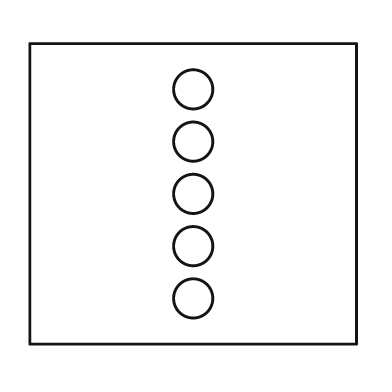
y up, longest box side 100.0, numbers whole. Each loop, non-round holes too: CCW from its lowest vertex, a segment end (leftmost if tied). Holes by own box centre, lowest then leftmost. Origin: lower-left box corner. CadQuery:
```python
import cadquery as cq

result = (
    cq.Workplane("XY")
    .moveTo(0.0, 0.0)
    .lineTo(100.0, 0.0)
    .lineTo(100.0, 92.0)
    .lineTo(0.0, 92.0)
    .close()
    .moveTo(50.0, 14.0)
    .circle(6.0)
    .moveTo(50.0, 30.0)
    .circle(6.0)
    .moveTo(50.0, 46.0)
    .circle(6.0)
    .moveTo(50.0, 62.0)
    .circle(6.0)
    .moveTo(50.0, 78.0)
    .circle(6.0)
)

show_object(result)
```